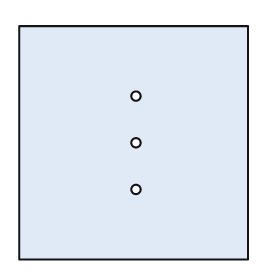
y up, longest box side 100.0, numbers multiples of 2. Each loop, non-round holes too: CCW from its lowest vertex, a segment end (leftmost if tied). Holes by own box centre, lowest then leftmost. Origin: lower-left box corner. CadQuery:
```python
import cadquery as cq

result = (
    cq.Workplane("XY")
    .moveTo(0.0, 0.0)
    .lineTo(98.0, 0.0)
    .lineTo(98.0, 100.0)
    .lineTo(0.0, 100.0)
    .close()
    .moveTo(50.0, 30.0)
    .circle(2.0)
    .moveTo(50.0, 50.0)
    .circle(2.0)
    .moveTo(50.0, 70.0)
    .circle(2.0)
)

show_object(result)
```